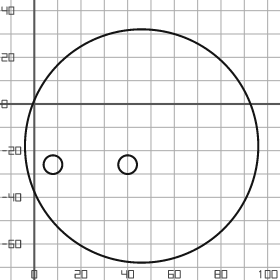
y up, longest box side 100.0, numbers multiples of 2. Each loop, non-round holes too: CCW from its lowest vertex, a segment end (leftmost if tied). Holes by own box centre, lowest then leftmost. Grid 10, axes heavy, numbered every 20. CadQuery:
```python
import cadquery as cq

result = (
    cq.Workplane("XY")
    .moveTo(46.0, -18.0)
    .circle(50.0)
    .moveTo(8.0, -26.0)
    .circle(4.0)
    .moveTo(40.0, -26.0)
    .circle(4.0)
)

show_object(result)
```